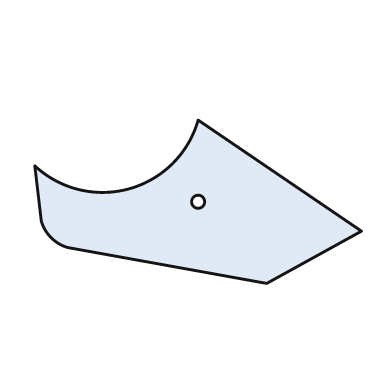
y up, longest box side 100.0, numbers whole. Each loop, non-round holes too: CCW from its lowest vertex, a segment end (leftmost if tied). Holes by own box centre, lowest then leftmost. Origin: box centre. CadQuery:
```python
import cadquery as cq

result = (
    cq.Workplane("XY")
    .moveTo(21.0, -25.0)
    .lineTo(50.0, -9.0)
    .lineTo(0.0, 25.0)
    .threePointArc((-21.0, 4.0), (-50.0, 11.0))
    .lineTo(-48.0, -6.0)
    .threePointArc((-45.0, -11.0), (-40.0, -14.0))
    .close()
    .moveTo(0.0, 0.0)
    .circle(2.0)
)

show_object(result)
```